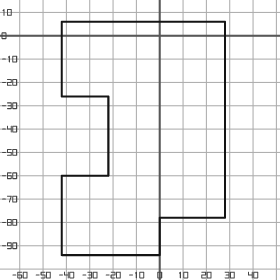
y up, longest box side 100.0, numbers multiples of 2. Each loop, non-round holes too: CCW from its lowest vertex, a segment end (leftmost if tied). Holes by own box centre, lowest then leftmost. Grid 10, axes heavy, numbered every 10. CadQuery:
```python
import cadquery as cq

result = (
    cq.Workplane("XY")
    .moveTo(-42.0, -94.0)
    .lineTo(0.0, -94.0)
    .lineTo(0.0, -78.0)
    .lineTo(28.0, -78.0)
    .lineTo(28.0, 6.0)
    .lineTo(-42.0, 6.0)
    .lineTo(-42.0, -26.0)
    .lineTo(-22.0, -26.0)
    .lineTo(-22.0, -60.0)
    .lineTo(-42.0, -60.0)
    .close()
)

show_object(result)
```